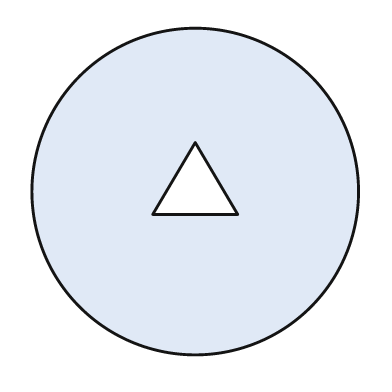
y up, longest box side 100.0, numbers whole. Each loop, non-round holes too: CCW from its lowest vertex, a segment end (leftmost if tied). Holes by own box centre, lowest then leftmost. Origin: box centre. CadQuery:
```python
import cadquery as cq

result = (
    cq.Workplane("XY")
    .moveTo(0.0, 0.0)
    .circle(50.0)
    .moveTo(-13.0, -7.0)
    .lineTo(13.0, -7.0)
    .lineTo(0.0, 15.0)
    .close()
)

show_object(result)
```